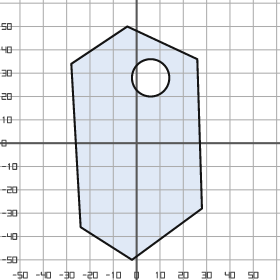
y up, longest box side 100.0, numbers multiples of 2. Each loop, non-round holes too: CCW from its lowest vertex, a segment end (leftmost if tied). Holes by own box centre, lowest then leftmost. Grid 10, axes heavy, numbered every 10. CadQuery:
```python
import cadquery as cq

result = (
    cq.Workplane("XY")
    .moveTo(-2.0, -50.0)
    .lineTo(28.0, -28.0)
    .lineTo(26.0, 36.0)
    .lineTo(-4.0, 50.0)
    .lineTo(-28.0, 34.0)
    .lineTo(-24.0, -36.0)
    .close()
    .moveTo(6.0, 28.0)
    .circle(8.0)
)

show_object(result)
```